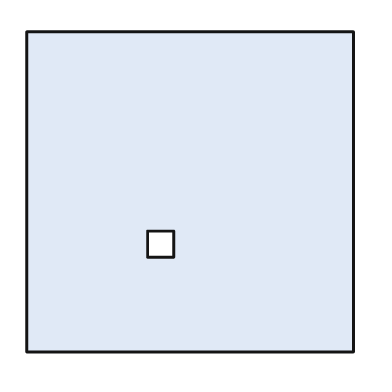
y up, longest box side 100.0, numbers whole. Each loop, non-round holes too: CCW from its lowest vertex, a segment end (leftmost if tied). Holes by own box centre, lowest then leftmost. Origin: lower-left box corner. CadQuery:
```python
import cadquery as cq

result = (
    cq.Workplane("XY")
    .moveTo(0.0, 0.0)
    .lineTo(100.0, 0.0)
    .lineTo(100.0, 98.0)
    .lineTo(0.0, 98.0)
    .close()
    .moveTo(37.0, 29.0)
    .lineTo(45.0, 29.0)
    .lineTo(45.0, 37.0)
    .lineTo(37.0, 37.0)
    .close()
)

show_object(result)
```